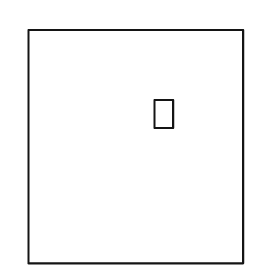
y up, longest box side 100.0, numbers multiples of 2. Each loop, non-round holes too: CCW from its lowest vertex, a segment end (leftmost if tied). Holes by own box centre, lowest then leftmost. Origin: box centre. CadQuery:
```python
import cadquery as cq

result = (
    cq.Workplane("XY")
    .moveTo(-46.0, -50.0)
    .lineTo(46.0, -50.0)
    .lineTo(46.0, 50.0)
    .lineTo(-46.0, 50.0)
    .close()
    .moveTo(8.0, 8.0)
    .lineTo(16.0, 8.0)
    .lineTo(16.0, 20.0)
    .lineTo(8.0, 20.0)
    .close()
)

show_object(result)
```